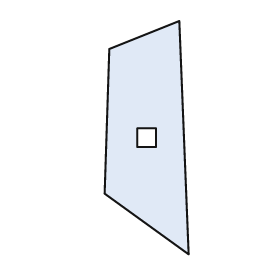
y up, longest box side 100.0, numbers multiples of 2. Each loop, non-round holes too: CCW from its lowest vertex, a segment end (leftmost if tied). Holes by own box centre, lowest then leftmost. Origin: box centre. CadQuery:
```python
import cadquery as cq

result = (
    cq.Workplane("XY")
    .moveTo(18.0, -50.0)
    .lineTo(14.0, 50.0)
    .lineTo(-16.0, 38.0)
    .lineTo(-18.0, -24.0)
    .close()
    .moveTo(-4.0, -4.0)
    .lineTo(4.0, -4.0)
    .lineTo(4.0, 4.0)
    .lineTo(-4.0, 4.0)
    .close()
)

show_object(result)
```